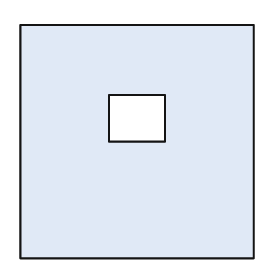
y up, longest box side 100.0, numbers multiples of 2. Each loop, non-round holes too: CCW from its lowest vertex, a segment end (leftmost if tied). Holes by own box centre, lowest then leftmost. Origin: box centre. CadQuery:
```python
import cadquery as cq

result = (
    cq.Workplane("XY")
    .moveTo(-50.0, -50.0)
    .lineTo(50.0, -50.0)
    .lineTo(50.0, 50.0)
    .lineTo(-50.0, 50.0)
    .close()
    .moveTo(-12.0, 0.0)
    .lineTo(12.0, 0.0)
    .lineTo(12.0, 20.0)
    .lineTo(-12.0, 20.0)
    .close()
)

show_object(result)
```